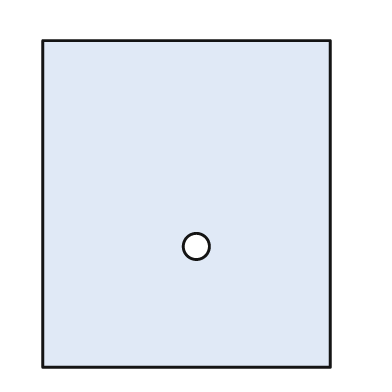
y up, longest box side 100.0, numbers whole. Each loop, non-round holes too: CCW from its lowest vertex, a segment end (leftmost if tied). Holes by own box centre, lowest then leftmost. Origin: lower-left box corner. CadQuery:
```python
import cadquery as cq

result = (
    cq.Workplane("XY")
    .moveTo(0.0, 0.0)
    .lineTo(88.0, 0.0)
    .lineTo(88.0, 100.0)
    .lineTo(0.0, 100.0)
    .close()
    .moveTo(47.0, 37.0)
    .circle(4.0)
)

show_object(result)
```